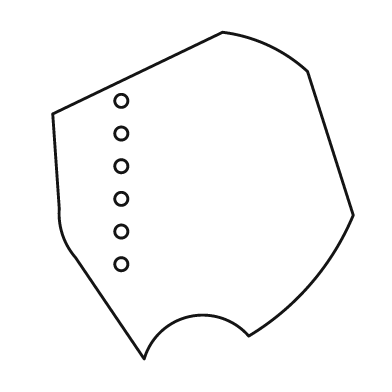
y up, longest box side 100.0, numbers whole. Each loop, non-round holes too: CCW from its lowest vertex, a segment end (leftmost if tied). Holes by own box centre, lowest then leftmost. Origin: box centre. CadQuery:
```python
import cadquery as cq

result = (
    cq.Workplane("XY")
    .moveTo(-18.0, -50.0)
    .threePointArc((-4.0, -37.0), (14.0, -43.0))
    .threePointArc((33.0, -27.0), (46.0, -6.0))
    .lineTo(32.0, 38.0)
    .threePointArc((20.0, 46.0), (6.0, 50.0))
    .lineTo(-46.0, 25.0)
    .lineTo(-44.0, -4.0)
    .threePointArc((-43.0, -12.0), (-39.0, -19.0))
    .close()
    .moveTo(-25.0, -21.0)
    .circle(2.0)
    .moveTo(-25.0, -11.0)
    .circle(2.0)
    .moveTo(-25.0, -1.0)
    .circle(2.0)
    .moveTo(-25.0, 9.0)
    .circle(2.0)
    .moveTo(-25.0, 19.0)
    .circle(2.0)
    .moveTo(-25.0, 29.0)
    .circle(2.0)
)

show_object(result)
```